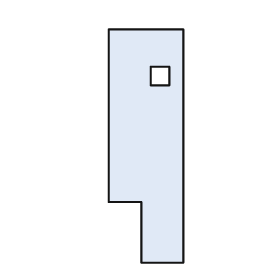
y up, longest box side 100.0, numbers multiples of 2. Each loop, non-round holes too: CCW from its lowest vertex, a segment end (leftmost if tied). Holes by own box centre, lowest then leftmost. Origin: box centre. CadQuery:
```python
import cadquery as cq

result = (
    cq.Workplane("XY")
    .moveTo(-2.0, -50.0)
    .lineTo(16.0, -50.0)
    .lineTo(16.0, 50.0)
    .lineTo(-16.0, 50.0)
    .lineTo(-16.0, -24.0)
    .lineTo(-2.0, -24.0)
    .close()
    .moveTo(2.0, 26.0)
    .lineTo(10.0, 26.0)
    .lineTo(10.0, 34.0)
    .lineTo(2.0, 34.0)
    .close()
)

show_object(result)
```